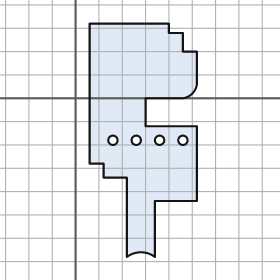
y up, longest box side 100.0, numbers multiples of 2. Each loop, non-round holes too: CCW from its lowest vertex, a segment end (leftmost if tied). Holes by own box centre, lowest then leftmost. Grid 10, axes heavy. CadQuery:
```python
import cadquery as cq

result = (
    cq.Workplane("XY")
    .moveTo(22.0, -68.0)
    .threePointArc((28.0, -66.0), (34.0, -68.0))
    .lineTo(34.0, -44.0)
    .lineTo(52.0, -44.0)
    .lineTo(52.0, -12.0)
    .lineTo(30.0, -12.0)
    .lineTo(30.0, 0.0)
    .lineTo(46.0, 0.0)
    .threePointArc((50.0, 2.0), (52.0, 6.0))
    .lineTo(52.0, 20.0)
    .lineTo(46.0, 20.0)
    .lineTo(46.0, 28.0)
    .lineTo(40.0, 28.0)
    .lineTo(40.0, 32.0)
    .lineTo(6.0, 32.0)
    .lineTo(6.0, -28.0)
    .lineTo(12.0, -28.0)
    .lineTo(12.0, -34.0)
    .lineTo(22.0, -34.0)
    .close()
    .moveTo(16.0, -18.0)
    .circle(2.0)
    .moveTo(26.0, -18.0)
    .circle(2.0)
    .moveTo(36.0, -18.0)
    .circle(2.0)
    .moveTo(46.0, -18.0)
    .circle(2.0)
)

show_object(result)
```